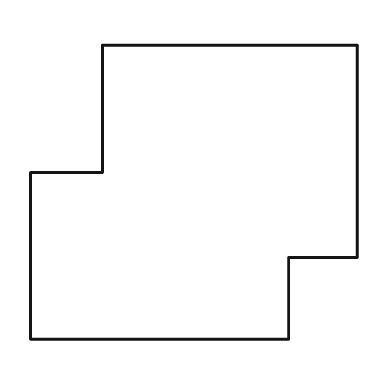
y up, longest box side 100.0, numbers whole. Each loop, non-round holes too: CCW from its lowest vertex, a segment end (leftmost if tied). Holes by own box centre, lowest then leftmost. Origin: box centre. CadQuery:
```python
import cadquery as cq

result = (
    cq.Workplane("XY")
    .moveTo(-50.0, -45.0)
    .lineTo(29.0, -45.0)
    .lineTo(29.0, -20.0)
    .lineTo(50.0, -20.0)
    .lineTo(50.0, 45.0)
    .lineTo(-28.0, 45.0)
    .lineTo(-28.0, 6.0)
    .lineTo(-50.0, 6.0)
    .close()
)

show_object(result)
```